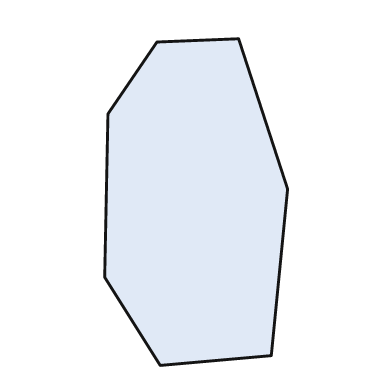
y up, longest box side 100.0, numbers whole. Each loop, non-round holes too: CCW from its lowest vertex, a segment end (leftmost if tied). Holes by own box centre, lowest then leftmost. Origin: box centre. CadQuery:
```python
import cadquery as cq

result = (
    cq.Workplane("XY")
    .moveTo(-11.0, -50.0)
    .lineTo(23.0, -47.0)
    .lineTo(28.0, 4.0)
    .lineTo(13.0, 50.0)
    .lineTo(-12.0, 49.0)
    .lineTo(-27.0, 27.0)
    .lineTo(-28.0, -23.0)
    .close()
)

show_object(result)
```